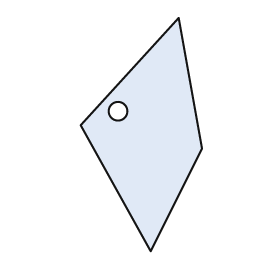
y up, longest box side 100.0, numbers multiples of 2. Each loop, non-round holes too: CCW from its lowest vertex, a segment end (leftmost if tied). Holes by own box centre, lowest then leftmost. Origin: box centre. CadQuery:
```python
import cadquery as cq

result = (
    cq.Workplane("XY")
    .moveTo(4.0, -50.0)
    .lineTo(26.0, -6.0)
    .lineTo(16.0, 50.0)
    .lineTo(-26.0, 4.0)
    .close()
    .moveTo(-10.0, 10.0)
    .circle(4.0)
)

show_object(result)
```